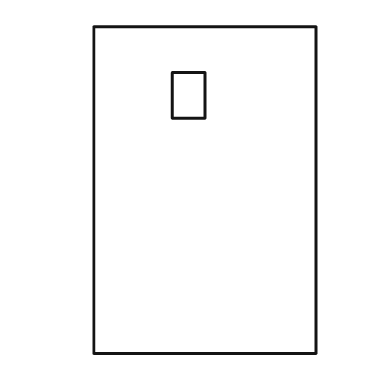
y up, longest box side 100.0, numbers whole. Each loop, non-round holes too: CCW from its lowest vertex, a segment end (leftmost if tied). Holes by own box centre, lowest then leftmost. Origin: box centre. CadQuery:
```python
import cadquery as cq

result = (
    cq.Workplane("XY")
    .moveTo(-34.0, -50.0)
    .lineTo(34.0, -50.0)
    .lineTo(34.0, 50.0)
    .lineTo(-34.0, 50.0)
    .close()
    .moveTo(-10.0, 22.0)
    .lineTo(0.0, 22.0)
    .lineTo(0.0, 36.0)
    .lineTo(-10.0, 36.0)
    .close()
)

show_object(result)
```